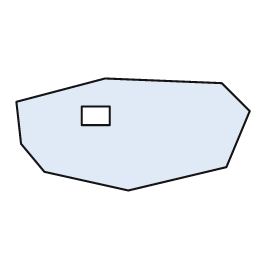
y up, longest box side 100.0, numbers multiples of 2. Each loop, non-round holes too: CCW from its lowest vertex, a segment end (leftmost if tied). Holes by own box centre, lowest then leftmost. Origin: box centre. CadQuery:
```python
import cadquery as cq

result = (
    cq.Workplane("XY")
    .moveTo(-2.0, -24.0)
    .lineTo(40.0, -14.0)
    .lineTo(50.0, 10.0)
    .lineTo(38.0, 22.0)
    .lineTo(-12.0, 24.0)
    .lineTo(-50.0, 14.0)
    .lineTo(-48.0, -4.0)
    .lineTo(-38.0, -16.0)
    .close()
    .moveTo(-22.0, 4.0)
    .lineTo(-10.0, 4.0)
    .lineTo(-10.0, 12.0)
    .lineTo(-22.0, 12.0)
    .close()
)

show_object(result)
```